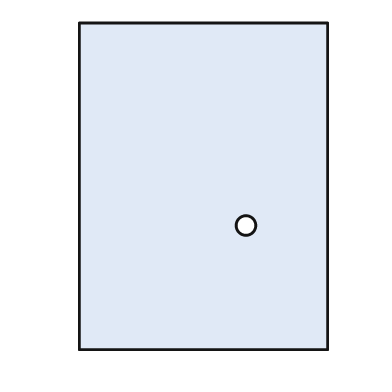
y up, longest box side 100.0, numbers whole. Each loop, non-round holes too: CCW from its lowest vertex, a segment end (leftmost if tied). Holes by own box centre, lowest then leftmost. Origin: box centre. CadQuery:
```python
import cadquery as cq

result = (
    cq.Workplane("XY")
    .moveTo(-38.0, -50.0)
    .lineTo(38.0, -50.0)
    .lineTo(38.0, 50.0)
    .lineTo(-38.0, 50.0)
    .close()
    .moveTo(13.0, -12.0)
    .circle(3.0)
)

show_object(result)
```